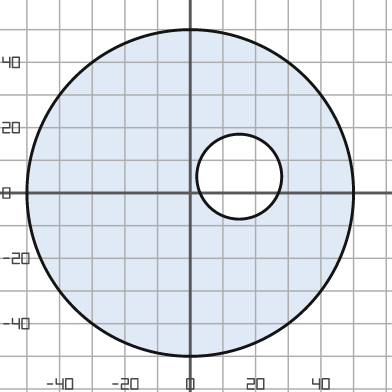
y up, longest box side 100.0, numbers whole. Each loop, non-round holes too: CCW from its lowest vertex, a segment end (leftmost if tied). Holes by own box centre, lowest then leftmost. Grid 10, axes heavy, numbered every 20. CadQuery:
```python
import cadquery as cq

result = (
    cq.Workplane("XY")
    .moveTo(0.0, 0.0)
    .circle(50.0)
    .moveTo(15.0, 5.0)
    .circle(13.0)
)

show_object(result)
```